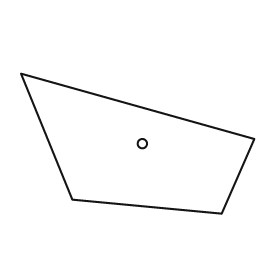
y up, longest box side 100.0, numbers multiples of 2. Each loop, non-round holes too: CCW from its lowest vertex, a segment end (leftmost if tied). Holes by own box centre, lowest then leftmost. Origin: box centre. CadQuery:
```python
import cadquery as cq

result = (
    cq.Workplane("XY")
    .moveTo(36.0, -30.0)
    .lineTo(50.0, 2.0)
    .lineTo(-50.0, 30.0)
    .lineTo(-28.0, -24.0)
    .close()
    .moveTo(2.0, 0.0)
    .circle(2.0)
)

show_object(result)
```